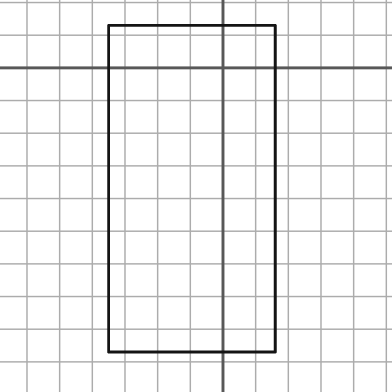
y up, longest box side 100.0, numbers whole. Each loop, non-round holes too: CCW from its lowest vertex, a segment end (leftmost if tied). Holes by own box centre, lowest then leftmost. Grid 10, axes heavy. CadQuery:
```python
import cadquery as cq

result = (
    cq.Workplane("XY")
    .moveTo(-35.0, -87.0)
    .lineTo(16.0, -87.0)
    .lineTo(16.0, 13.0)
    .lineTo(-35.0, 13.0)
    .close()
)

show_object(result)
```